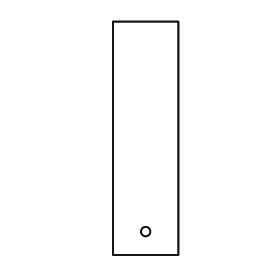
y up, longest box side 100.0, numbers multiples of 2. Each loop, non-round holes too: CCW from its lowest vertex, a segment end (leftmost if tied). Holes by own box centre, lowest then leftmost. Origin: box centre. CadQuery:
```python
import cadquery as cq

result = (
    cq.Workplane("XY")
    .moveTo(-14.0, -50.0)
    .lineTo(14.0, -50.0)
    .lineTo(14.0, 50.0)
    .lineTo(-14.0, 50.0)
    .close()
    .moveTo(0.0, -40.0)
    .circle(2.0)
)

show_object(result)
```